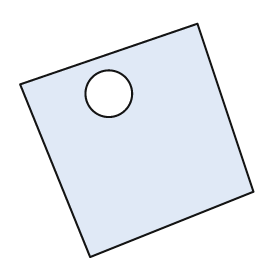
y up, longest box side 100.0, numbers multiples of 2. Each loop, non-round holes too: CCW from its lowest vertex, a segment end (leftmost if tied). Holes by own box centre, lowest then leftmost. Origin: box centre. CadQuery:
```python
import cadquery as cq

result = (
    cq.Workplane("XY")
    .moveTo(-20.0, -50.0)
    .lineTo(50.0, -22.0)
    .lineTo(26.0, 50.0)
    .lineTo(-50.0, 24.0)
    .close()
    .moveTo(-12.0, 20.0)
    .circle(10.0)
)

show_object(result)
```